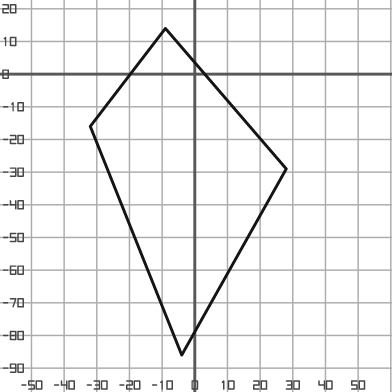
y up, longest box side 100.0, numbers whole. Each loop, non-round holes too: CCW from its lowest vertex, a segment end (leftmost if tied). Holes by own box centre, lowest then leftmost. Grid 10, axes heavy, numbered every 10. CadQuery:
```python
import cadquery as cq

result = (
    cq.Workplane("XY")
    .moveTo(-4.0, -86.0)
    .lineTo(28.0, -29.0)
    .lineTo(-9.0, 14.0)
    .lineTo(-32.0, -16.0)
    .close()
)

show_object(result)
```